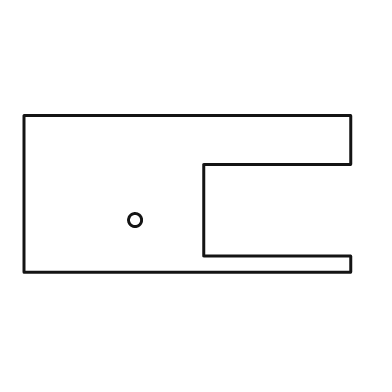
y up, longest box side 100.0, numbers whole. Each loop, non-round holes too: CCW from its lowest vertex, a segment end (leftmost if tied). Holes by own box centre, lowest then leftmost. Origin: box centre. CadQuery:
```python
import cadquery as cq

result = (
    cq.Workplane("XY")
    .moveTo(-50.0, -24.0)
    .lineTo(50.0, -24.0)
    .lineTo(50.0, -19.0)
    .lineTo(5.0, -19.0)
    .lineTo(5.0, 9.0)
    .lineTo(50.0, 9.0)
    .lineTo(50.0, 24.0)
    .lineTo(-50.0, 24.0)
    .close()
    .moveTo(-16.0, -8.0)
    .circle(2.0)
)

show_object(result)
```